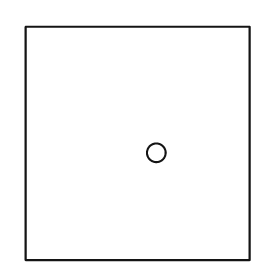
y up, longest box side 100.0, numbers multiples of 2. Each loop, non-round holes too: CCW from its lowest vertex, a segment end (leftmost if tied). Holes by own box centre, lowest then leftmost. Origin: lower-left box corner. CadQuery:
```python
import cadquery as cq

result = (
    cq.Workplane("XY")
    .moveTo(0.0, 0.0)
    .lineTo(96.0, 0.0)
    .lineTo(96.0, 100.0)
    .lineTo(0.0, 100.0)
    .close()
    .moveTo(56.0, 46.0)
    .circle(4.0)
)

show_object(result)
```